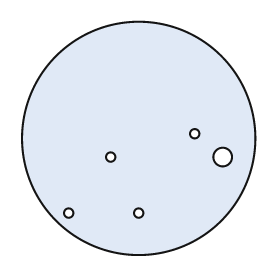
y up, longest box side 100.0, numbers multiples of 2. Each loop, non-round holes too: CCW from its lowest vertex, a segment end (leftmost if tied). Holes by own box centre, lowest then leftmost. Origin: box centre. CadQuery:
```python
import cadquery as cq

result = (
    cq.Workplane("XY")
    .moveTo(0.0, 0.0)
    .circle(50.0)
    .moveTo(-30.0, -32.0)
    .circle(2.0)
    .moveTo(0.0, -32.0)
    .circle(2.0)
    .moveTo(-12.0, -8.0)
    .circle(2.0)
    .moveTo(36.0, -8.0)
    .circle(4.0)
    .moveTo(24.0, 2.0)
    .circle(2.0)
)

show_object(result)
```